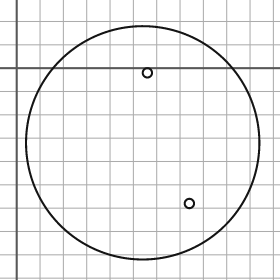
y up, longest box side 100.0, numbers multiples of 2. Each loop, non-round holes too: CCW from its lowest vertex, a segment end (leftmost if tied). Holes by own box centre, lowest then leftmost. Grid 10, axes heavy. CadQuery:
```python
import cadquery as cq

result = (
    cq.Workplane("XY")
    .moveTo(54.0, -32.0)
    .circle(50.0)
    .moveTo(74.0, -58.0)
    .circle(2.0)
    .moveTo(56.0, -2.0)
    .circle(2.0)
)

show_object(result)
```